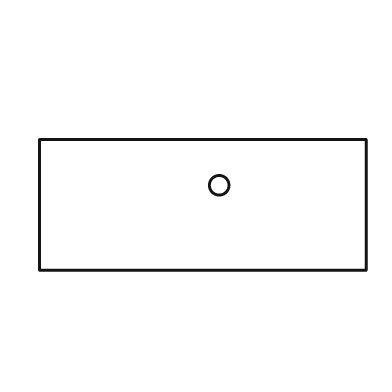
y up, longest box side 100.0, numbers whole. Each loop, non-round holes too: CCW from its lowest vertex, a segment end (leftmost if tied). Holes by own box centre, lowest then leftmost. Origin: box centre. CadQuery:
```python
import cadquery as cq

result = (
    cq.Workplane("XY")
    .moveTo(-50.0, -20.0)
    .lineTo(50.0, -20.0)
    .lineTo(50.0, 20.0)
    .lineTo(-50.0, 20.0)
    .close()
    .moveTo(5.0, 6.0)
    .circle(3.0)
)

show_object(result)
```